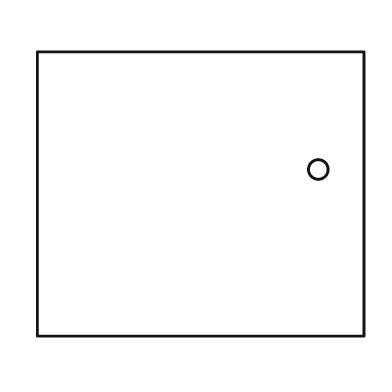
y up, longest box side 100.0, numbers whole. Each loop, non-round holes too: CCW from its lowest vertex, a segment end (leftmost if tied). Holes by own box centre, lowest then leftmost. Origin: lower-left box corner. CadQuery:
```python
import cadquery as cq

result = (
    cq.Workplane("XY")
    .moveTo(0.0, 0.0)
    .lineTo(100.0, 0.0)
    .lineTo(100.0, 87.0)
    .lineTo(0.0, 87.0)
    .close()
    .moveTo(86.0, 51.0)
    .circle(3.0)
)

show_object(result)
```